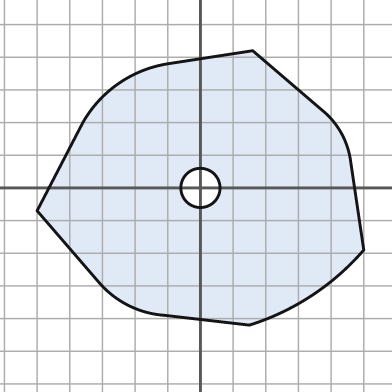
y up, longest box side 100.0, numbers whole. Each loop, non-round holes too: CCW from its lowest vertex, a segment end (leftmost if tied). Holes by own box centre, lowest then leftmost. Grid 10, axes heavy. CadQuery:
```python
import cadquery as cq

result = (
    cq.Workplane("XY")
    .moveTo(15.0, -42.0)
    .threePointArc((34.0, -33.0), (50.0, -19.0))
    .lineTo(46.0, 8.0)
    .threePointArc((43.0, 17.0), (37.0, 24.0))
    .lineTo(16.0, 42.0)
    .lineTo(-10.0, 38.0)
    .threePointArc((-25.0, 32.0), (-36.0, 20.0))
    .lineTo(-50.0, -7.0)
    .lineTo(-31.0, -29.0)
    .threePointArc((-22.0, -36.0), (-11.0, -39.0))
    .close()
    .moveTo(0.0, 0.0)
    .circle(6.0)
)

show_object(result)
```